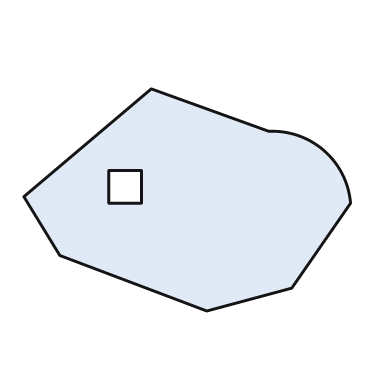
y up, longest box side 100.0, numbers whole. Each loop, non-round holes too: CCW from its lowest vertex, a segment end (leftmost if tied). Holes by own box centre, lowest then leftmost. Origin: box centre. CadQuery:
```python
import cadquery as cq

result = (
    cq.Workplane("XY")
    .moveTo(6.0, -34.0)
    .lineTo(32.0, -27.0)
    .lineTo(50.0, -1.0)
    .threePointArc((42.0, 15.0), (25.0, 21.0))
    .lineTo(-11.0, 34.0)
    .lineTo(-50.0, 1.0)
    .lineTo(-39.0, -17.0)
    .close()
    .moveTo(-24.0, -1.0)
    .lineTo(-14.0, -1.0)
    .lineTo(-14.0, 9.0)
    .lineTo(-24.0, 9.0)
    .close()
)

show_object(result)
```